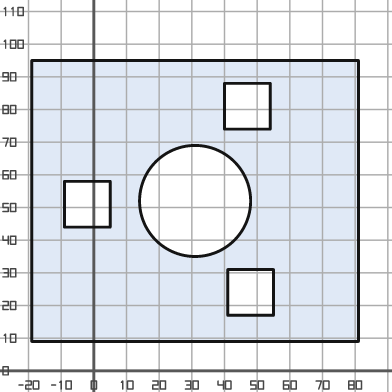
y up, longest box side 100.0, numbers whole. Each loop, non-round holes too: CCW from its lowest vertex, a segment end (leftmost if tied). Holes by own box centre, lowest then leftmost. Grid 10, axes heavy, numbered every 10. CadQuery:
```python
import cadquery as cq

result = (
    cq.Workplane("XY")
    .moveTo(-19.0, 9.0)
    .lineTo(81.0, 9.0)
    .lineTo(81.0, 95.0)
    .lineTo(-19.0, 95.0)
    .close()
    .moveTo(41.0, 17.0)
    .lineTo(55.0, 17.0)
    .lineTo(55.0, 31.0)
    .lineTo(41.0, 31.0)
    .close()
    .moveTo(-9.0, 44.0)
    .lineTo(5.0, 44.0)
    .lineTo(5.0, 58.0)
    .lineTo(-9.0, 58.0)
    .close()
    .moveTo(31.0, 52.0)
    .circle(17.0)
    .moveTo(40.0, 74.0)
    .lineTo(54.0, 74.0)
    .lineTo(54.0, 88.0)
    .lineTo(40.0, 88.0)
    .close()
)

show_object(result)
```